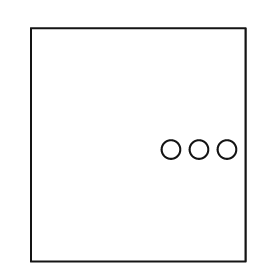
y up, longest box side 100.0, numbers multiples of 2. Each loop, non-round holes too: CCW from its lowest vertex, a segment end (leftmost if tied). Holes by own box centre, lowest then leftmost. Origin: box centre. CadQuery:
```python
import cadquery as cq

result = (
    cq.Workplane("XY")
    .moveTo(-46.0, -50.0)
    .lineTo(46.0, -50.0)
    .lineTo(46.0, 50.0)
    .lineTo(-46.0, 50.0)
    .close()
    .moveTo(14.0, -2.0)
    .circle(4.0)
    .moveTo(26.0, -2.0)
    .circle(4.0)
    .moveTo(38.0, -2.0)
    .circle(4.0)
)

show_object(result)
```